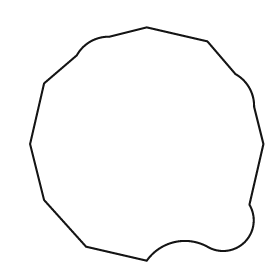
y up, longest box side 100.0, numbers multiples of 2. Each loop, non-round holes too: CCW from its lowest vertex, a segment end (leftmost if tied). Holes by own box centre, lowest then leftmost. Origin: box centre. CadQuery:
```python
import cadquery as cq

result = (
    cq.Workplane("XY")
    .moveTo(0.0, -50.0)
    .threePointArc((12.0, -42.0), (26.0, -44.0))
    .threePointArc((42.0, -42.0), (44.0, -26.0))
    .lineTo(50.0, 0.0)
    .lineTo(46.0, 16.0)
    .threePointArc((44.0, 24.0), (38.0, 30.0))
    .lineTo(26.0, 44.0)
    .lineTo(0.0, 50.0)
    .lineTo(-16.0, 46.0)
    .threePointArc((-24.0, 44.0), (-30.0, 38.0))
    .lineTo(-44.0, 26.0)
    .lineTo(-50.0, 0.0)
    .lineTo(-44.0, -24.0)
    .lineTo(-26.0, -44.0)
    .close()
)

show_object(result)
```